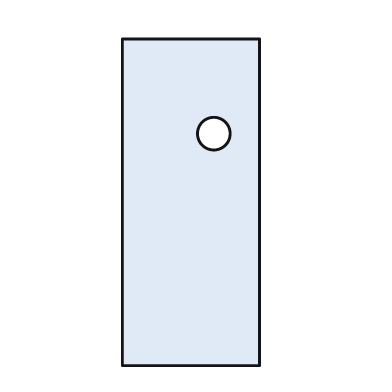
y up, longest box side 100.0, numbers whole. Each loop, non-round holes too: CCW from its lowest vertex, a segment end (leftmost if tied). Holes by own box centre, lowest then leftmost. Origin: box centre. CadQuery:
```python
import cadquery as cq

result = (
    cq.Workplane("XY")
    .moveTo(-21.0, -50.0)
    .lineTo(21.0, -50.0)
    .lineTo(21.0, 50.0)
    .lineTo(-21.0, 50.0)
    .close()
    .moveTo(7.0, 21.0)
    .circle(5.0)
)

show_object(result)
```